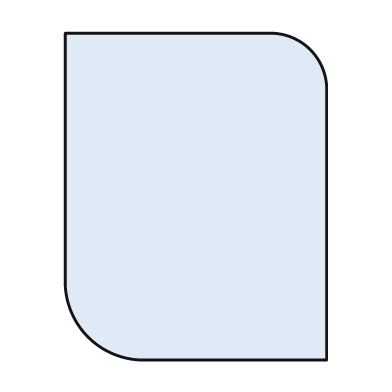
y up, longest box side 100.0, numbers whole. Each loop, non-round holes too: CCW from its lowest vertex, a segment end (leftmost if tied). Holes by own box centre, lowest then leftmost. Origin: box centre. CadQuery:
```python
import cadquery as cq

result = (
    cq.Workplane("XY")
    .moveTo(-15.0, -50.0)
    .lineTo(40.0, -50.0)
    .lineTo(40.0, 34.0)
    .threePointArc((35.0, 45.0), (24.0, 50.0))
    .lineTo(-40.0, 50.0)
    .lineTo(-40.0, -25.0)
    .threePointArc((-33.0, -43.0), (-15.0, -50.0))
    .close()
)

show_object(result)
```